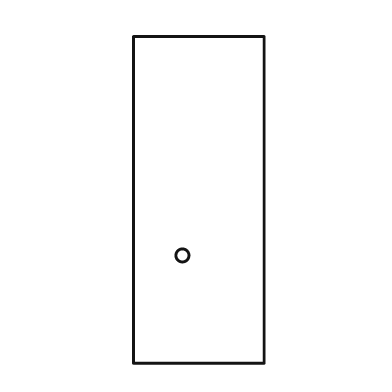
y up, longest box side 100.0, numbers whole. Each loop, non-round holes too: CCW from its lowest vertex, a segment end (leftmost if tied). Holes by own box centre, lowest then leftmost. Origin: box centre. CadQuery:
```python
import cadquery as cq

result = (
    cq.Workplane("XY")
    .moveTo(-20.0, -50.0)
    .lineTo(20.0, -50.0)
    .lineTo(20.0, 50.0)
    .lineTo(-20.0, 50.0)
    .close()
    .moveTo(-5.0, -17.0)
    .circle(2.0)
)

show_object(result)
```